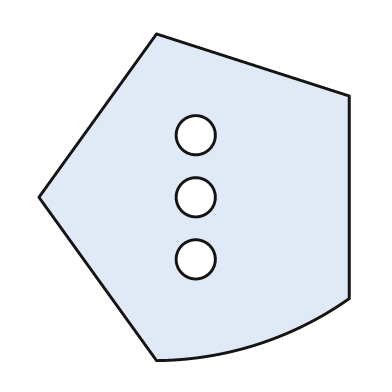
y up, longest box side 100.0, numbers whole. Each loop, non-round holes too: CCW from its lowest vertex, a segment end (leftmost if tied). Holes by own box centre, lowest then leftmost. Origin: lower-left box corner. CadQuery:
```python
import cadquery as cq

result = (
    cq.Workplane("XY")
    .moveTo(36.0, 0.0)
    .threePointArc((67.0, 5.0), (95.0, 19.0))
    .lineTo(95.0, 81.0)
    .lineTo(36.0, 100.0)
    .lineTo(0.0, 50.0)
    .close()
    .moveTo(48.0, 31.0)
    .circle(6.0)
    .moveTo(48.0, 50.0)
    .circle(6.0)
    .moveTo(48.0, 69.0)
    .circle(6.0)
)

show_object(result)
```